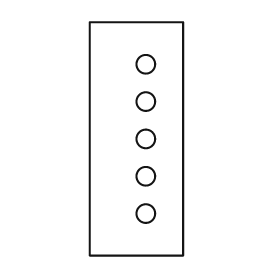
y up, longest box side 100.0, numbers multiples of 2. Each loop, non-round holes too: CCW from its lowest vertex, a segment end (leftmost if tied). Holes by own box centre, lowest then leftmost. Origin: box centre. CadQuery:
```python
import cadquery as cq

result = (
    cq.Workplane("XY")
    .moveTo(-20.0, -50.0)
    .lineTo(20.0, -50.0)
    .lineTo(20.0, 50.0)
    .lineTo(-20.0, 50.0)
    .close()
    .moveTo(4.0, -32.0)
    .circle(4.0)
    .moveTo(4.0, -16.0)
    .circle(4.0)
    .moveTo(4.0, 0.0)
    .circle(4.0)
    .moveTo(4.0, 16.0)
    .circle(4.0)
    .moveTo(4.0, 32.0)
    .circle(4.0)
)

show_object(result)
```